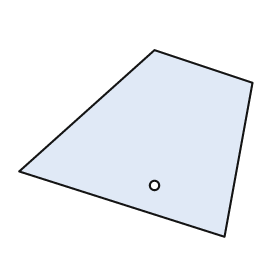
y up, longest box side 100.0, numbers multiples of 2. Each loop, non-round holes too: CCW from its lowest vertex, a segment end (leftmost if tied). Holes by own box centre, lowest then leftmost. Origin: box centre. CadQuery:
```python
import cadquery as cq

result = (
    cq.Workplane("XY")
    .moveTo(38.0, -40.0)
    .lineTo(50.0, 26.0)
    .lineTo(8.0, 40.0)
    .lineTo(-50.0, -12.0)
    .close()
    .moveTo(8.0, -18.0)
    .circle(2.0)
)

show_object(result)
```